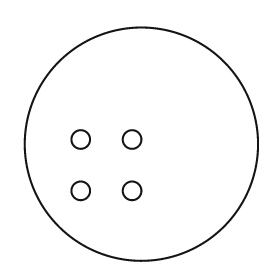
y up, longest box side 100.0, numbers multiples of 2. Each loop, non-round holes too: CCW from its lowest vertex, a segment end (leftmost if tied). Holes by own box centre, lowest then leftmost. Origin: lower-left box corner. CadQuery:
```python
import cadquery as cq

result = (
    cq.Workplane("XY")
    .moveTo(50.0, 50.0)
    .circle(50.0)
    .moveTo(24.0, 30.0)
    .circle(4.0)
    .moveTo(46.0, 30.0)
    .circle(4.0)
    .moveTo(24.0, 52.0)
    .circle(4.0)
    .moveTo(46.0, 52.0)
    .circle(4.0)
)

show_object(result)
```